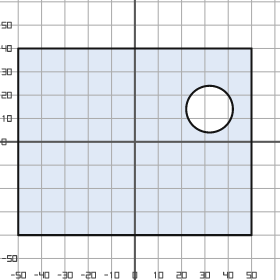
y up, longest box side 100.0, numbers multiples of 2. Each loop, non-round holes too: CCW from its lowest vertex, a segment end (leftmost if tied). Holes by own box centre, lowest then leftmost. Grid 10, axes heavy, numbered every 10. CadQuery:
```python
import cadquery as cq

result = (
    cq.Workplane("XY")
    .moveTo(-50.0, -40.0)
    .lineTo(50.0, -40.0)
    .lineTo(50.0, 40.0)
    .lineTo(-50.0, 40.0)
    .close()
    .moveTo(32.0, 14.0)
    .circle(10.0)
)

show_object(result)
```